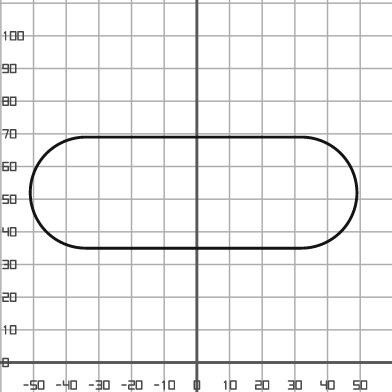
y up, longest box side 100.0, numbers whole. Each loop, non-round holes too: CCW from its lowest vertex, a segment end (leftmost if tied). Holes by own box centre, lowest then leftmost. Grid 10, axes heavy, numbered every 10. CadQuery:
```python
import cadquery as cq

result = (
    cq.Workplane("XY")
    .moveTo(-34.0, 35.0)
    .lineTo(32.0, 35.0)
    .threePointArc((49.0, 52.0), (32.0, 69.0))
    .lineTo(-34.0, 69.0)
    .threePointArc((-51.0, 52.0), (-34.0, 35.0))
    .close()
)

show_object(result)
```